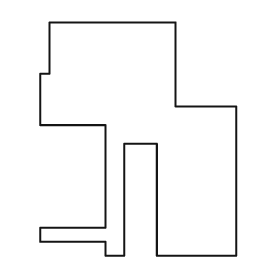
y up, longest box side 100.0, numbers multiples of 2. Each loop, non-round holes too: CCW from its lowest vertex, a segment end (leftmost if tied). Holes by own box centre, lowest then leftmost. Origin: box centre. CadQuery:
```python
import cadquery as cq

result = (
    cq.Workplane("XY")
    .moveTo(-14.0, -50.0)
    .lineTo(-6.0, -50.0)
    .lineTo(-6.0, -2.0)
    .lineTo(8.0, -2.0)
    .lineTo(8.0, -50.0)
    .lineTo(42.0, -50.0)
    .lineTo(42.0, 14.0)
    .lineTo(16.0, 14.0)
    .lineTo(16.0, 50.0)
    .lineTo(-38.0, 50.0)
    .lineTo(-38.0, 28.0)
    .lineTo(-42.0, 28.0)
    .lineTo(-42.0, 6.0)
    .lineTo(-14.0, 6.0)
    .lineTo(-14.0, -38.0)
    .lineTo(-42.0, -38.0)
    .lineTo(-42.0, -44.0)
    .lineTo(-14.0, -44.0)
    .close()
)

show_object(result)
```